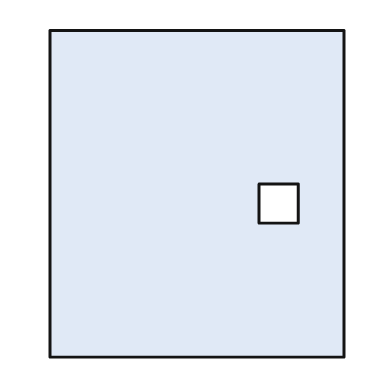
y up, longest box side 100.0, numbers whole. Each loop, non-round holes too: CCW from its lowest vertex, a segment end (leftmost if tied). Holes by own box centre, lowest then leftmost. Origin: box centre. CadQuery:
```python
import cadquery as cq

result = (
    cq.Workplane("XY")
    .moveTo(-45.0, -50.0)
    .lineTo(45.0, -50.0)
    .lineTo(45.0, 50.0)
    .lineTo(-45.0, 50.0)
    .close()
    .moveTo(19.0, -9.0)
    .lineTo(31.0, -9.0)
    .lineTo(31.0, 3.0)
    .lineTo(19.0, 3.0)
    .close()
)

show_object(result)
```